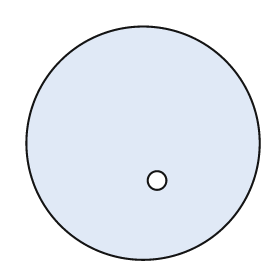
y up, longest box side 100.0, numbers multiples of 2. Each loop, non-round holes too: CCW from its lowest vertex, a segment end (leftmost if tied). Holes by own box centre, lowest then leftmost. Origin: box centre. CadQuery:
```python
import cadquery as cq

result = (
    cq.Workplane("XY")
    .moveTo(0.0, 0.0)
    .circle(50.0)
    .moveTo(6.0, -16.0)
    .circle(4.0)
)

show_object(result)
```